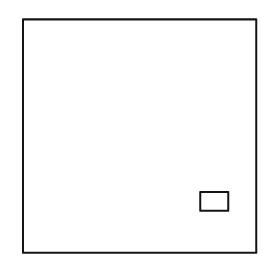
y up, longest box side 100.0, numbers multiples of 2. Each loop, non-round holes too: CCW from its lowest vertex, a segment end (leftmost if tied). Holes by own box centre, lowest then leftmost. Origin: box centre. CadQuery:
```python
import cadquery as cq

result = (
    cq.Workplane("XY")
    .moveTo(-50.0, -50.0)
    .lineTo(50.0, -50.0)
    .lineTo(50.0, 50.0)
    .lineTo(-50.0, 50.0)
    .close()
    .moveTo(26.0, -32.0)
    .lineTo(38.0, -32.0)
    .lineTo(38.0, -24.0)
    .lineTo(26.0, -24.0)
    .close()
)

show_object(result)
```